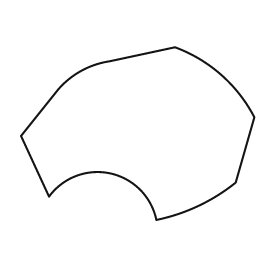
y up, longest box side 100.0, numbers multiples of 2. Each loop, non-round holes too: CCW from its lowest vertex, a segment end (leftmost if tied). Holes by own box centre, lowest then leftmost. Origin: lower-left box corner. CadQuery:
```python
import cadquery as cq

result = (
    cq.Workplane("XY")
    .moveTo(58.0, 0.0)
    .threePointArc((76.0, 6.0), (92.0, 16.0))
    .lineTo(100.0, 44.0)
    .threePointArc((86.0, 62.0), (66.0, 74.0))
    .lineTo(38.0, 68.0)
    .threePointArc((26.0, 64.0), (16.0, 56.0))
    .lineTo(0.0, 36.0)
    .lineTo(12.0, 10.0)
    .threePointArc((38.0, 20.0), (58.0, 0.0))
    .close()
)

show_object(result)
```